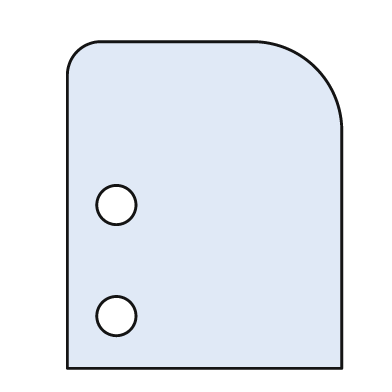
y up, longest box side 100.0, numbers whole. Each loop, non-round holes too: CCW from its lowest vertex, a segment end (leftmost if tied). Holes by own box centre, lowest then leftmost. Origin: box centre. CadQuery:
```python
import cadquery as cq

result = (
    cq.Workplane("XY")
    .moveTo(-42.0, -50.0)
    .lineTo(42.0, -50.0)
    .lineTo(42.0, 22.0)
    .threePointArc((34.0, 42.0), (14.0, 50.0))
    .lineTo(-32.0, 50.0)
    .threePointArc((-39.0, 47.0), (-42.0, 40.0))
    .close()
    .moveTo(-27.0, -34.0)
    .circle(6.0)
    .moveTo(-27.0, 0.0)
    .circle(6.0)
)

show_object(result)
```